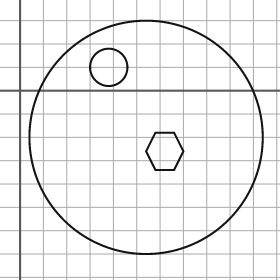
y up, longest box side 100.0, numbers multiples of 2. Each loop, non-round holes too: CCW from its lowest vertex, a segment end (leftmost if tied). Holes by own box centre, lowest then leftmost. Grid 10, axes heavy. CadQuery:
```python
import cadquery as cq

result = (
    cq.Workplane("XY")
    .moveTo(54.0, -20.0)
    .circle(50.0)
    .moveTo(58.0, -34.0)
    .lineTo(66.0, -34.0)
    .lineTo(70.0, -26.0)
    .lineTo(66.0, -18.0)
    .lineTo(58.0, -18.0)
    .lineTo(54.0, -26.0)
    .close()
    .moveTo(38.0, 10.0)
    .circle(8.0)
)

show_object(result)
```